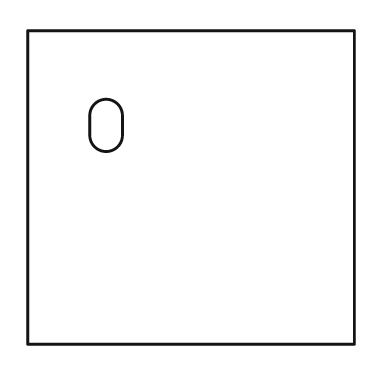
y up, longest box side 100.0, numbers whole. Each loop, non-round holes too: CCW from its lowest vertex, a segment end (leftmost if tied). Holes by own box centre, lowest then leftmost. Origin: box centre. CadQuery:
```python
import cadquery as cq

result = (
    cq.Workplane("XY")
    .moveTo(-50.0, -48.0)
    .lineTo(50.0, -48.0)
    .lineTo(50.0, 48.0)
    .lineTo(-50.0, 48.0)
    .close()
    .moveTo(-31.0, 16.0)
    .threePointArc((-26.0, 11.0), (-21.0, 16.0))
    .lineTo(-21.0, 22.0)
    .threePointArc((-26.0, 27.0), (-31.0, 22.0))
    .close()
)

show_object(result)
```